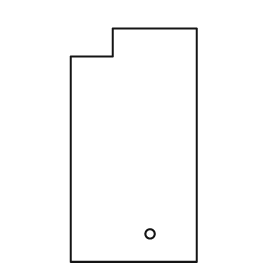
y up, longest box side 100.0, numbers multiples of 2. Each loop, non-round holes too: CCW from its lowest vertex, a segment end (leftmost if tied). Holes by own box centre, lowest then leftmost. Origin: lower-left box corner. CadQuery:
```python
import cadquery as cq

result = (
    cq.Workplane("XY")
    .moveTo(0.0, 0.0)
    .lineTo(54.0, 0.0)
    .lineTo(54.0, 100.0)
    .lineTo(18.0, 100.0)
    .lineTo(18.0, 88.0)
    .lineTo(0.0, 88.0)
    .close()
    .moveTo(34.0, 12.0)
    .circle(2.0)
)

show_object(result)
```